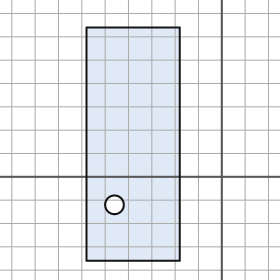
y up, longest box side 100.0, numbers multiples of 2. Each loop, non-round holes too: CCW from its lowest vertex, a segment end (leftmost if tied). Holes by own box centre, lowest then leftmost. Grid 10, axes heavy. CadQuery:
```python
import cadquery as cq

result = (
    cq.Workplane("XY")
    .moveTo(-58.0, -36.0)
    .lineTo(-18.0, -36.0)
    .lineTo(-18.0, 64.0)
    .lineTo(-58.0, 64.0)
    .close()
    .moveTo(-46.0, -12.0)
    .circle(4.0)
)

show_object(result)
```